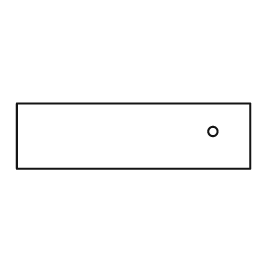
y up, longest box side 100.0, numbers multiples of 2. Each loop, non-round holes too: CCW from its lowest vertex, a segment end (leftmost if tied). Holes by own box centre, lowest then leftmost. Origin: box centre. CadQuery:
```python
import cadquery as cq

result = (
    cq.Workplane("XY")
    .moveTo(-50.0, -14.0)
    .lineTo(50.0, -14.0)
    .lineTo(50.0, 14.0)
    .lineTo(-50.0, 14.0)
    .close()
    .moveTo(34.0, 2.0)
    .circle(2.0)
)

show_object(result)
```